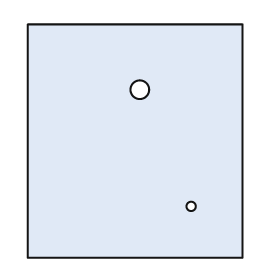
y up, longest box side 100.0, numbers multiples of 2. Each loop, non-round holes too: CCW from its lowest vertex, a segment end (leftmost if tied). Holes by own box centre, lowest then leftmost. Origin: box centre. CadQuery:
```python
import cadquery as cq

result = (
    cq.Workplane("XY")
    .moveTo(-46.0, -50.0)
    .lineTo(46.0, -50.0)
    .lineTo(46.0, 50.0)
    .lineTo(-46.0, 50.0)
    .close()
    .moveTo(24.0, -28.0)
    .circle(2.0)
    .moveTo(2.0, 22.0)
    .circle(4.0)
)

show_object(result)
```